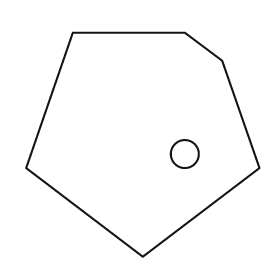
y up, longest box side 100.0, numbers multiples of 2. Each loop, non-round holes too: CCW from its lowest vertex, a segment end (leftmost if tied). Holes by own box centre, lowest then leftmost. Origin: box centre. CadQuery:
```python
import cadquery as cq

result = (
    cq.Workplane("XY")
    .moveTo(0.0, -48.0)
    .lineTo(50.0, -10.0)
    .lineTo(34.0, 36.0)
    .lineTo(18.0, 48.0)
    .lineTo(-30.0, 48.0)
    .lineTo(-50.0, -10.0)
    .close()
    .moveTo(18.0, -4.0)
    .circle(6.0)
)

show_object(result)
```